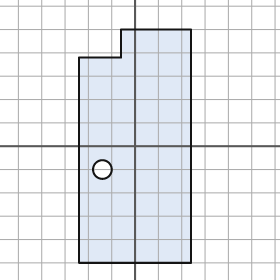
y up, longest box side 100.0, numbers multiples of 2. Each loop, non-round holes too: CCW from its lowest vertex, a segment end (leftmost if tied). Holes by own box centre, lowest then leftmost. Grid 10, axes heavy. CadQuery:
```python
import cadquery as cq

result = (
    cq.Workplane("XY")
    .moveTo(-24.0, -50.0)
    .lineTo(24.0, -50.0)
    .lineTo(24.0, 50.0)
    .lineTo(-6.0, 50.0)
    .lineTo(-6.0, 38.0)
    .lineTo(-24.0, 38.0)
    .close()
    .moveTo(-14.0, -10.0)
    .circle(4.0)
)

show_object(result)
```